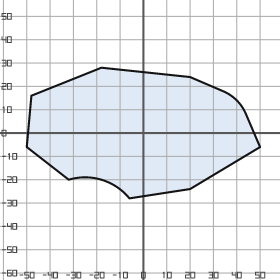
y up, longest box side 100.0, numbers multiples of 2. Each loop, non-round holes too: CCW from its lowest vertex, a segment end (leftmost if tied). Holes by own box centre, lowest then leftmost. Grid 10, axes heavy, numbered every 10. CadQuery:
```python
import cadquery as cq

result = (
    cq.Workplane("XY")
    .moveTo(-6.0, -28.0)
    .lineTo(20.0, -24.0)
    .lineTo(50.0, -6.0)
    .lineTo(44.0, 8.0)
    .threePointArc((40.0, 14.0), (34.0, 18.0))
    .lineTo(20.0, 24.0)
    .lineTo(-18.0, 28.0)
    .lineTo(-48.0, 16.0)
    .lineTo(-50.0, -6.0)
    .lineTo(-32.0, -20.0)
    .threePointArc((-18.0, -20.0), (-6.0, -28.0))
    .close()
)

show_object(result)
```